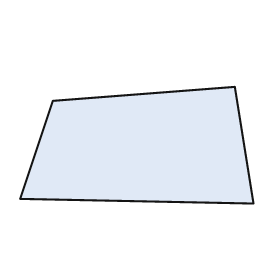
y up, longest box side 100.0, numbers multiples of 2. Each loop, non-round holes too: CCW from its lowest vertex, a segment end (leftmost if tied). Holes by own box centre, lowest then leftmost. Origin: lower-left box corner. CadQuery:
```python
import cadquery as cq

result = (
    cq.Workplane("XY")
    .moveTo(100.0, 0.0)
    .lineTo(92.0, 50.0)
    .lineTo(14.0, 44.0)
    .lineTo(0.0, 2.0)
    .close()
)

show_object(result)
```